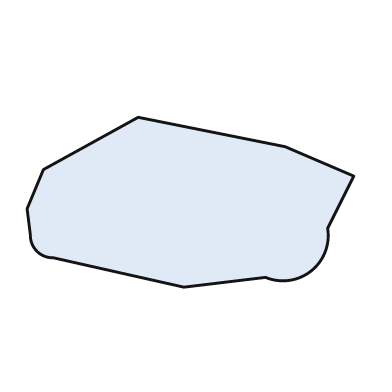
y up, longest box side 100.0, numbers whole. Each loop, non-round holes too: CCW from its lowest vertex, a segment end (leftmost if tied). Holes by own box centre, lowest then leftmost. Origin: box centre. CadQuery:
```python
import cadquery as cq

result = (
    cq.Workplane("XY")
    .moveTo(-2.0, -26.0)
    .lineTo(23.0, -23.0)
    .threePointArc((37.0, -21.0), (42.0, -8.0))
    .lineTo(50.0, 8.0)
    .lineTo(29.0, 17.0)
    .lineTo(-16.0, 26.0)
    .lineTo(-45.0, 10.0)
    .lineTo(-50.0, -2.0)
    .lineTo(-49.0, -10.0)
    .threePointArc((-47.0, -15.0), (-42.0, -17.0))
    .close()
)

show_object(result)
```